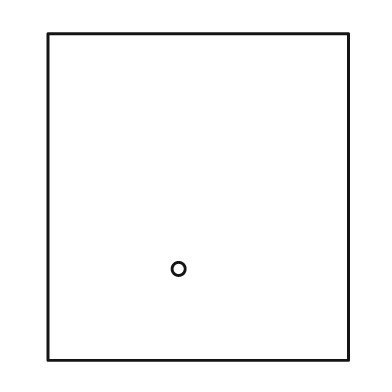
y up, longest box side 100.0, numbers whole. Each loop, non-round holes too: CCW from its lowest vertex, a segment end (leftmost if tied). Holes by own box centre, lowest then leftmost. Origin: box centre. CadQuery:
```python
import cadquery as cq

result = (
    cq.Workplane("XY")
    .moveTo(-46.0, -50.0)
    .lineTo(46.0, -50.0)
    .lineTo(46.0, 50.0)
    .lineTo(-46.0, 50.0)
    .close()
    .moveTo(-6.0, -22.0)
    .circle(2.0)
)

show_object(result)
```